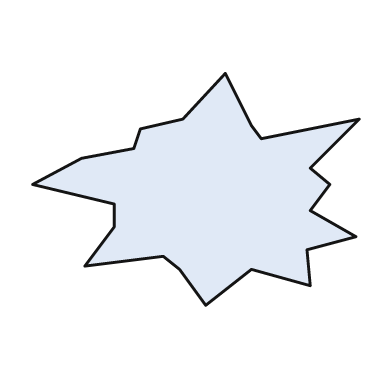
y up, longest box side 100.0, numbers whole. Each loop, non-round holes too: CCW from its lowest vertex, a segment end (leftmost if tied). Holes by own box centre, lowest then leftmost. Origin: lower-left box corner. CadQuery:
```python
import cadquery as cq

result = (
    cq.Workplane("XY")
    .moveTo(53.0, 0.0)
    .lineTo(67.0, 11.0)
    .lineTo(85.0, 6.0)
    .lineTo(84.0, 17.0)
    .lineTo(99.0, 21.0)
    .lineTo(85.0, 29.0)
    .lineTo(91.0, 37.0)
    .lineTo(85.0, 42.0)
    .lineTo(100.0, 57.0)
    .lineTo(70.0, 51.0)
    .lineTo(67.0, 55.0)
    .lineTo(59.0, 71.0)
    .lineTo(46.0, 57.0)
    .lineTo(33.0, 54.0)
    .lineTo(31.0, 48.0)
    .lineTo(15.0, 45.0)
    .lineTo(0.0, 37.0)
    .lineTo(25.0, 31.0)
    .lineTo(25.0, 24.0)
    .lineTo(16.0, 12.0)
    .lineTo(40.0, 15.0)
    .lineTo(45.0, 11.0)
    .close()
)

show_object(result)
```